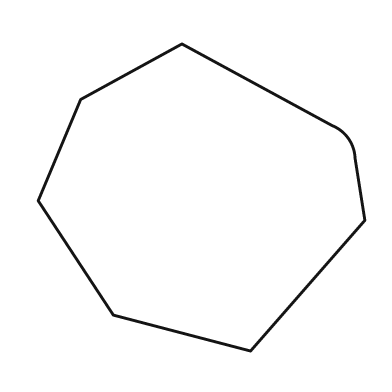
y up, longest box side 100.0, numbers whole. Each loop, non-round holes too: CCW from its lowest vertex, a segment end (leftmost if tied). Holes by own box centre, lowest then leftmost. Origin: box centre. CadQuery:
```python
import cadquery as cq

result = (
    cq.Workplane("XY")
    .moveTo(15.0, -47.0)
    .lineTo(50.0, -7.0)
    .lineTo(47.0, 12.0)
    .threePointArc((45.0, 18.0), (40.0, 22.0))
    .lineTo(-6.0, 47.0)
    .lineTo(-37.0, 30.0)
    .lineTo(-50.0, -1.0)
    .lineTo(-27.0, -36.0)
    .close()
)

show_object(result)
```